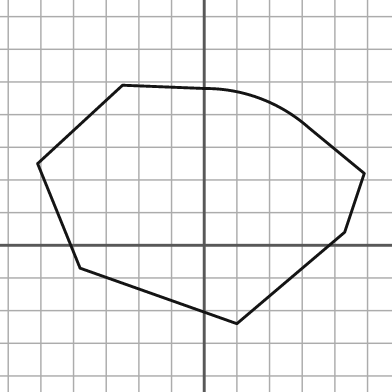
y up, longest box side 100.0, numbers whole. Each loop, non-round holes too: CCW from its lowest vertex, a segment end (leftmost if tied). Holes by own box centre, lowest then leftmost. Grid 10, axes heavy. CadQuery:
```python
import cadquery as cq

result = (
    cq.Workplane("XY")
    .moveTo(10.0, -24.0)
    .lineTo(43.0, 4.0)
    .lineTo(49.0, 22.0)
    .lineTo(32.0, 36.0)
    .threePointArc((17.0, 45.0), (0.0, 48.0))
    .lineTo(-25.0, 49.0)
    .lineTo(-51.0, 25.0)
    .lineTo(-38.0, -7.0)
    .close()
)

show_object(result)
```